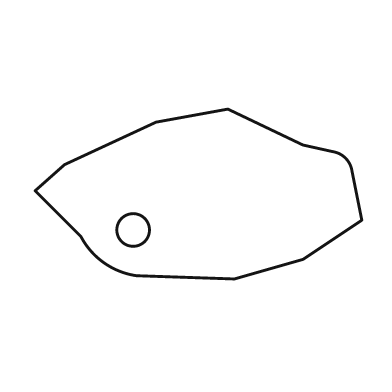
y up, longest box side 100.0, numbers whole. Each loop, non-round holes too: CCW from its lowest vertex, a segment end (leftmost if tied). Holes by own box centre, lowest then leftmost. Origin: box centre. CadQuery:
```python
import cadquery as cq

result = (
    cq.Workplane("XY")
    .moveTo(11.0, -26.0)
    .lineTo(32.0, -20.0)
    .lineTo(50.0, -8.0)
    .lineTo(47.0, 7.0)
    .threePointArc((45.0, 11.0), (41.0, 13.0))
    .lineTo(32.0, 15.0)
    .lineTo(9.0, 26.0)
    .lineTo(-13.0, 22.0)
    .lineTo(-41.0, 9.0)
    .lineTo(-50.0, 1.0)
    .lineTo(-36.0, -13.0)
    .threePointArc((-29.0, -21.0), (-19.0, -25.0))
    .close()
    .moveTo(-20.0, -11.0)
    .circle(5.0)
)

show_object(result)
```